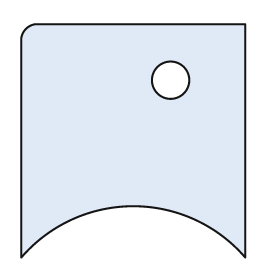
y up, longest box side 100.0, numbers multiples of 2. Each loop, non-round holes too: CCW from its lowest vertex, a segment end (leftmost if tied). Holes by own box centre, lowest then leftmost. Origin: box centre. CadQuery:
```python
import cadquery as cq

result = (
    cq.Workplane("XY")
    .moveTo(-48.0, -50.0)
    .threePointArc((0.0, -28.0), (48.0, -50.0))
    .lineTo(48.0, 50.0)
    .lineTo(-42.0, 50.0)
    .threePointArc((-46.0, 48.0), (-48.0, 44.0))
    .close()
    .moveTo(16.0, 26.0)
    .circle(8.0)
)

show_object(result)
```